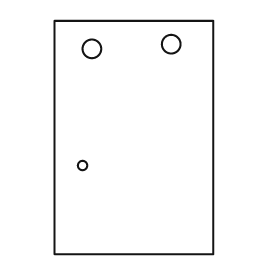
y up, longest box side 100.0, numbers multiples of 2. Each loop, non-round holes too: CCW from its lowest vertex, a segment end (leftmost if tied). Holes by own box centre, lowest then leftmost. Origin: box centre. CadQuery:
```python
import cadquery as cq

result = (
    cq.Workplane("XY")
    .moveTo(-34.0, -50.0)
    .lineTo(34.0, -50.0)
    .lineTo(34.0, 50.0)
    .lineTo(-34.0, 50.0)
    .close()
    .moveTo(-22.0, -12.0)
    .circle(2.0)
    .moveTo(-18.0, 38.0)
    .circle(4.0)
    .moveTo(16.0, 40.0)
    .circle(4.0)
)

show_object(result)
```